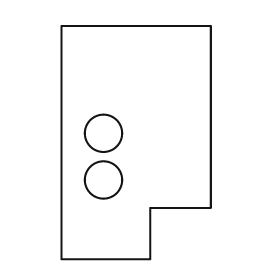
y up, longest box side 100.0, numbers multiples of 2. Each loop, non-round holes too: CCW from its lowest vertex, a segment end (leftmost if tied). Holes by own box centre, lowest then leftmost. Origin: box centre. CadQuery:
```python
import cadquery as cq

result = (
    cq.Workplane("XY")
    .moveTo(-32.0, -50.0)
    .lineTo(6.0, -50.0)
    .lineTo(6.0, -28.0)
    .lineTo(32.0, -28.0)
    .lineTo(32.0, 50.0)
    .lineTo(-32.0, 50.0)
    .close()
    .moveTo(-14.0, -16.0)
    .circle(8.0)
    .moveTo(-14.0, 4.0)
    .circle(8.0)
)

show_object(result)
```